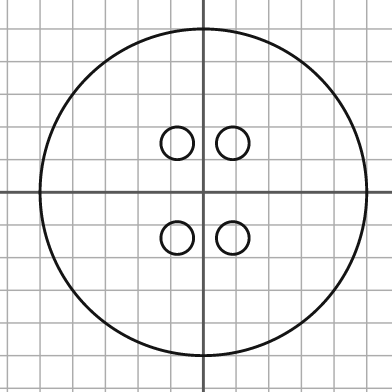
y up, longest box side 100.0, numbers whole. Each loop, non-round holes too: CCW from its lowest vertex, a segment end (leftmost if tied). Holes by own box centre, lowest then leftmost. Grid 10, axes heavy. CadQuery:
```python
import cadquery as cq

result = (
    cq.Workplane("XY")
    .moveTo(0.0, 0.0)
    .circle(50.0)
    .moveTo(-8.0, -14.0)
    .circle(5.0)
    .moveTo(9.0, -14.0)
    .circle(5.0)
    .moveTo(-8.0, 15.0)
    .circle(5.0)
    .moveTo(9.0, 15.0)
    .circle(5.0)
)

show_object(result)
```